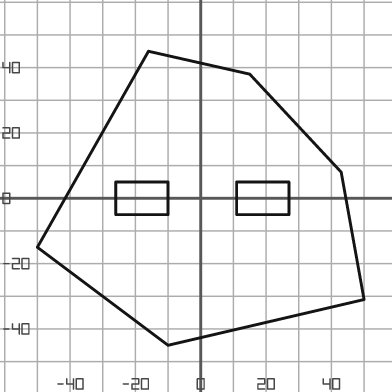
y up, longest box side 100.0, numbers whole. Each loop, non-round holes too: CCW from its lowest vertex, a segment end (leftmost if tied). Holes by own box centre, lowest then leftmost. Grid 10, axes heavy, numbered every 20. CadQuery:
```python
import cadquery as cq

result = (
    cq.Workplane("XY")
    .moveTo(-10.0, -45.0)
    .lineTo(50.0, -31.0)
    .lineTo(43.0, 8.0)
    .lineTo(15.0, 38.0)
    .lineTo(-16.0, 45.0)
    .lineTo(-50.0, -15.0)
    .close()
    .moveTo(-26.0, -5.0)
    .lineTo(-10.0, -5.0)
    .lineTo(-10.0, 5.0)
    .lineTo(-26.0, 5.0)
    .close()
    .moveTo(11.0, -5.0)
    .lineTo(27.0, -5.0)
    .lineTo(27.0, 5.0)
    .lineTo(11.0, 5.0)
    .close()
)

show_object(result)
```